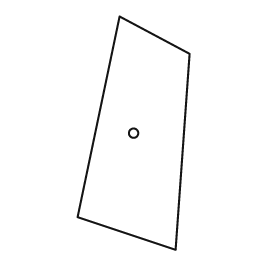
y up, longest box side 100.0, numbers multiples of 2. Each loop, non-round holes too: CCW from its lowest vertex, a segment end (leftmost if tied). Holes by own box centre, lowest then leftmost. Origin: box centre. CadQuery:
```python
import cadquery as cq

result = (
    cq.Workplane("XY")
    .moveTo(18.0, -50.0)
    .lineTo(24.0, 34.0)
    .lineTo(-6.0, 50.0)
    .lineTo(-24.0, -36.0)
    .close()
    .moveTo(0.0, 0.0)
    .circle(2.0)
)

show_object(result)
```